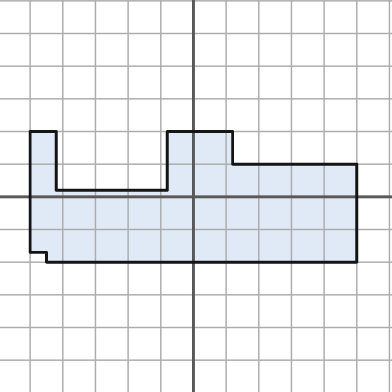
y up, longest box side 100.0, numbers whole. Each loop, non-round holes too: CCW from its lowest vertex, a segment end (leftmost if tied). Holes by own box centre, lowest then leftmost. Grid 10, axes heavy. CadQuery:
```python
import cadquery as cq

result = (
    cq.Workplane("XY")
    .moveTo(-45.0, -20.0)
    .lineTo(50.0, -20.0)
    .lineTo(50.0, 10.0)
    .lineTo(12.0, 10.0)
    .lineTo(12.0, 20.0)
    .lineTo(-8.0, 20.0)
    .lineTo(-8.0, 2.0)
    .lineTo(-42.0, 2.0)
    .lineTo(-42.0, 20.0)
    .lineTo(-50.0, 20.0)
    .lineTo(-50.0, -17.0)
    .lineTo(-45.0, -17.0)
    .close()
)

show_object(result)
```